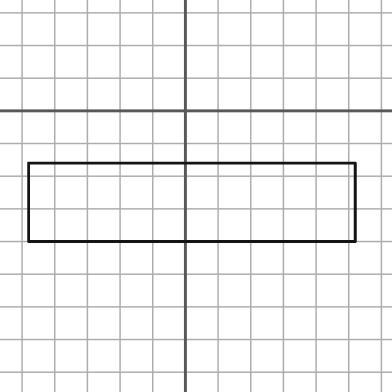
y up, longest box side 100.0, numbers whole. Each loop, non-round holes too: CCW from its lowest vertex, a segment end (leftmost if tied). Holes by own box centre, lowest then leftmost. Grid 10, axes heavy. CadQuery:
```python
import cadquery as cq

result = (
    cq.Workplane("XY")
    .moveTo(-48.0, -40.0)
    .lineTo(52.0, -40.0)
    .lineTo(52.0, -16.0)
    .lineTo(-48.0, -16.0)
    .close()
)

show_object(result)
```